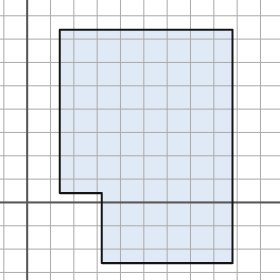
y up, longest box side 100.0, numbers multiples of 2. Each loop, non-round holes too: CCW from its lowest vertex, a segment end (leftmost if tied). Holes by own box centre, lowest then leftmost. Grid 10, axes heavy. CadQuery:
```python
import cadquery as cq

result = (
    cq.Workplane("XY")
    .moveTo(32.0, -26.0)
    .lineTo(88.0, -26.0)
    .lineTo(88.0, 74.0)
    .lineTo(14.0, 74.0)
    .lineTo(14.0, 4.0)
    .lineTo(32.0, 4.0)
    .close()
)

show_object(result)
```